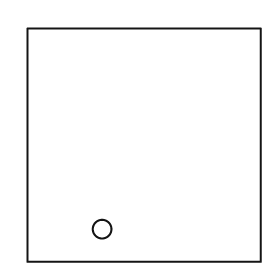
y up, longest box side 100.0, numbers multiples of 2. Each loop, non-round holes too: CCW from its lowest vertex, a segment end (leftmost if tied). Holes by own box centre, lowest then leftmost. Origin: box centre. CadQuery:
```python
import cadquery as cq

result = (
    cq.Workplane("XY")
    .moveTo(-50.0, -50.0)
    .lineTo(50.0, -50.0)
    .lineTo(50.0, 50.0)
    .lineTo(-50.0, 50.0)
    .close()
    .moveTo(-18.0, -36.0)
    .circle(4.0)
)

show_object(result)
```